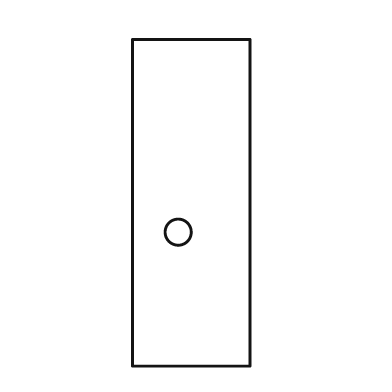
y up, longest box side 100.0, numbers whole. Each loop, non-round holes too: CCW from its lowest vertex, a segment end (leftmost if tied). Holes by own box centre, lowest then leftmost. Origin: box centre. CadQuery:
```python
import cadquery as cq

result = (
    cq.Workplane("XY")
    .moveTo(-18.0, -50.0)
    .lineTo(18.0, -50.0)
    .lineTo(18.0, 50.0)
    .lineTo(-18.0, 50.0)
    .close()
    .moveTo(-4.0, -9.0)
    .circle(4.0)
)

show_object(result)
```